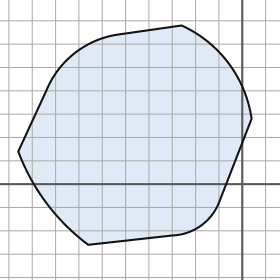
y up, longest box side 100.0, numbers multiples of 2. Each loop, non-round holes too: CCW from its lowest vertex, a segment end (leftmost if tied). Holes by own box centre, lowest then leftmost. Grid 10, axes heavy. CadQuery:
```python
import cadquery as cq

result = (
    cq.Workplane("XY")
    .moveTo(-66.0, -26.0)
    .lineTo(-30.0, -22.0)
    .threePointArc((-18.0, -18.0), (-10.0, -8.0))
    .lineTo(4.0, 28.0)
    .threePointArc((-6.0, 52.0), (-26.0, 68.0))
    .lineTo(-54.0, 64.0)
    .threePointArc((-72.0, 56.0), (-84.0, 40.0))
    .lineTo(-96.0, 14.0)
    .threePointArc((-84.0, -8.0), (-66.0, -26.0))
    .close()
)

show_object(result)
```